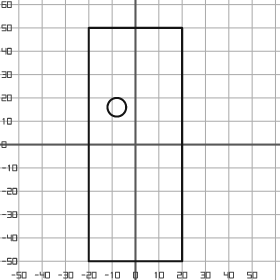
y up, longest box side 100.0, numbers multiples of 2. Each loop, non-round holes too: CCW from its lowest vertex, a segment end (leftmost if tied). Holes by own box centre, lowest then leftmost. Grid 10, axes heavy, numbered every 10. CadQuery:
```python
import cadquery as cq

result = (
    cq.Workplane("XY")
    .moveTo(-20.0, -50.0)
    .lineTo(20.0, -50.0)
    .lineTo(20.0, 50.0)
    .lineTo(-20.0, 50.0)
    .close()
    .moveTo(-8.0, 16.0)
    .circle(4.0)
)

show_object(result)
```